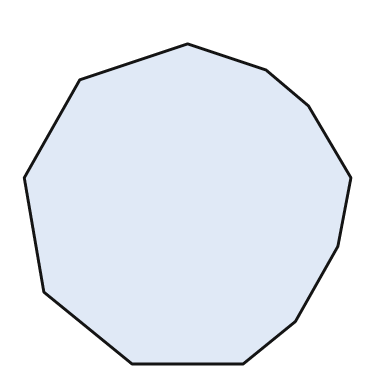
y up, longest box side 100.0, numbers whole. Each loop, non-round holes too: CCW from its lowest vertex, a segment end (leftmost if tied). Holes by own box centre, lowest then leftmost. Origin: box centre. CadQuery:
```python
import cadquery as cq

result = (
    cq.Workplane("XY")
    .moveTo(-17.0, -49.0)
    .lineTo(17.0, -49.0)
    .lineTo(33.0, -36.0)
    .lineTo(46.0, -13.0)
    .lineTo(50.0, 8.0)
    .lineTo(37.0, 30.0)
    .lineTo(24.0, 41.0)
    .lineTo(0.0, 49.0)
    .lineTo(-33.0, 38.0)
    .lineTo(-50.0, 8.0)
    .lineTo(-44.0, -27.0)
    .close()
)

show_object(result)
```